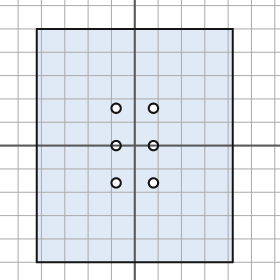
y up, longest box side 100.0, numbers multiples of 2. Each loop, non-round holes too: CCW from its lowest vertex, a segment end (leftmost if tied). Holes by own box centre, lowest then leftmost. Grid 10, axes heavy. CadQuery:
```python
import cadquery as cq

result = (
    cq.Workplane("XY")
    .moveTo(-42.0, -50.0)
    .lineTo(42.0, -50.0)
    .lineTo(42.0, 50.0)
    .lineTo(-42.0, 50.0)
    .close()
    .moveTo(-8.0, -16.0)
    .circle(2.0)
    .moveTo(8.0, -16.0)
    .circle(2.0)
    .moveTo(-8.0, 0.0)
    .circle(2.0)
    .moveTo(8.0, 0.0)
    .circle(2.0)
    .moveTo(-8.0, 16.0)
    .circle(2.0)
    .moveTo(8.0, 16.0)
    .circle(2.0)
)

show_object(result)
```